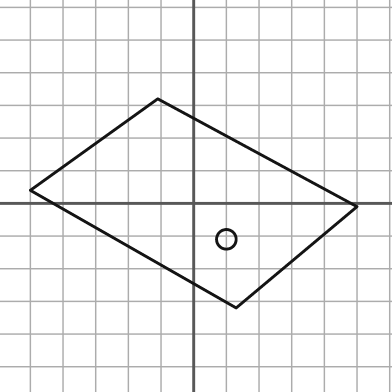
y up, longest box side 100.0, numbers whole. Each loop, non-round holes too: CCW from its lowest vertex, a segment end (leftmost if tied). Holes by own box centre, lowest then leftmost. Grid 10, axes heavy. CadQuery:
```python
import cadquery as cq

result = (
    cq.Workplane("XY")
    .moveTo(13.0, -32.0)
    .lineTo(50.0, -1.0)
    .lineTo(-11.0, 32.0)
    .lineTo(-50.0, 4.0)
    .close()
    .moveTo(10.0, -11.0)
    .circle(3.0)
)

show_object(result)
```